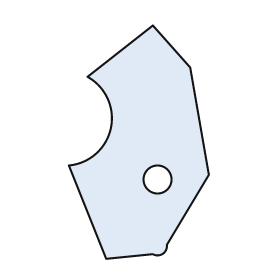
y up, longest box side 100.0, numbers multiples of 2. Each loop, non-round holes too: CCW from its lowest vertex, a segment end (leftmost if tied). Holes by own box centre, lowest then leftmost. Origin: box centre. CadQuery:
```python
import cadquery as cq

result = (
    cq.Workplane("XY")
    .moveTo(-14.0, -50.0)
    .lineTo(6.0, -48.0)
    .threePointArc((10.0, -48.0), (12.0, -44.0))
    .lineTo(30.0, -14.0)
    .lineTo(22.0, 32.0)
    .lineTo(6.0, 50.0)
    .lineTo(-22.0, 28.0)
    .threePointArc((-12.0, 6.0), (-30.0, -10.0))
    .close()
    .moveTo(8.0, -16.0)
    .circle(6.0)
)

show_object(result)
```